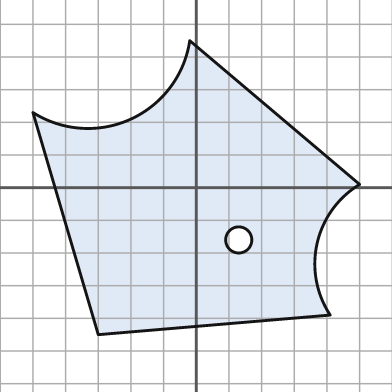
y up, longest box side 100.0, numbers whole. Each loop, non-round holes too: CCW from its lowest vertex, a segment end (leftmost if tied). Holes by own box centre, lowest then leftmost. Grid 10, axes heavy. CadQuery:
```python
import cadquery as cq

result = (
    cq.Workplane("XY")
    .moveTo(-30.0, -45.0)
    .lineTo(41.0, -39.0)
    .threePointArc((37.0, -17.0), (50.0, 1.0))
    .lineTo(-2.0, 45.0)
    .threePointArc((-20.0, 21.0), (-50.0, 23.0))
    .close()
    .moveTo(13.0, -16.0)
    .circle(4.0)
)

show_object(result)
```